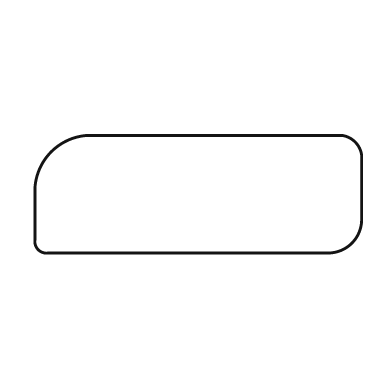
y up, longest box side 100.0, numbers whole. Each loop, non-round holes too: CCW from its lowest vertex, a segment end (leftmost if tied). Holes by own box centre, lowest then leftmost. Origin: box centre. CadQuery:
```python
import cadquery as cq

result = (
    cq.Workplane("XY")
    .moveTo(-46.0, -18.0)
    .lineTo(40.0, -18.0)
    .threePointArc((47.0, -15.0), (50.0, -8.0))
    .lineTo(50.0, 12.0)
    .threePointArc((48.0, 16.0), (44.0, 18.0))
    .lineTo(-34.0, 18.0)
    .threePointArc((-45.0, 13.0), (-50.0, 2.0))
    .lineTo(-50.0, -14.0)
    .threePointArc((-49.0, -17.0), (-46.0, -18.0))
    .close()
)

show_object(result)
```